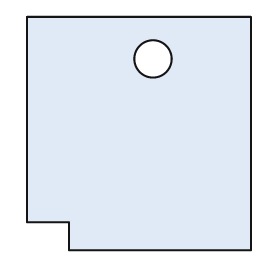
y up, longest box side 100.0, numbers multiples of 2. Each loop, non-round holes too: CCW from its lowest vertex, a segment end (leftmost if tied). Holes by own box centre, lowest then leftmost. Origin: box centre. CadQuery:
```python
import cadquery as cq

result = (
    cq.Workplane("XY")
    .moveTo(-30.0, -50.0)
    .lineTo(48.0, -50.0)
    .lineTo(48.0, 50.0)
    .lineTo(-48.0, 50.0)
    .lineTo(-48.0, -38.0)
    .lineTo(-30.0, -38.0)
    .close()
    .moveTo(6.0, 32.0)
    .circle(8.0)
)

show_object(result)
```